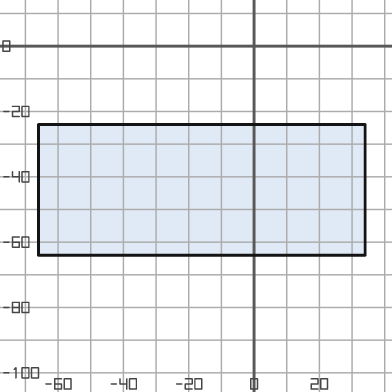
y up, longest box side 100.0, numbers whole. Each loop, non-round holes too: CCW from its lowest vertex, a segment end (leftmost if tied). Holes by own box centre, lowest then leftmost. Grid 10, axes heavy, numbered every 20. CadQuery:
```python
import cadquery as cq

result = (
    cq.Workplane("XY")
    .moveTo(-66.0, -64.0)
    .lineTo(34.0, -64.0)
    .lineTo(34.0, -24.0)
    .lineTo(-66.0, -24.0)
    .close()
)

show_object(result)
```